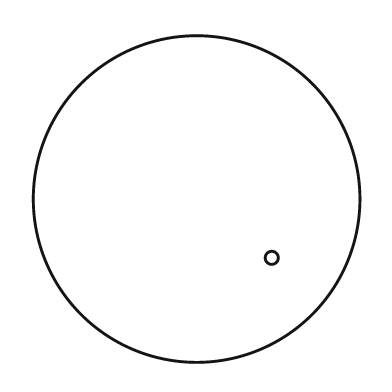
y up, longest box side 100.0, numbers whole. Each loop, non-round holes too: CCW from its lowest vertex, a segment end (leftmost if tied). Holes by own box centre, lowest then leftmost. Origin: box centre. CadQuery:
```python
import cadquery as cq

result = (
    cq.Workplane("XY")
    .moveTo(0.0, 0.0)
    .circle(50.0)
    .moveTo(23.0, -18.0)
    .circle(2.0)
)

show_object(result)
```